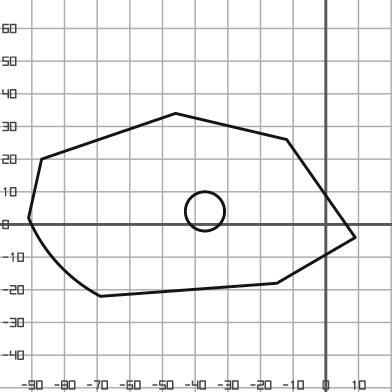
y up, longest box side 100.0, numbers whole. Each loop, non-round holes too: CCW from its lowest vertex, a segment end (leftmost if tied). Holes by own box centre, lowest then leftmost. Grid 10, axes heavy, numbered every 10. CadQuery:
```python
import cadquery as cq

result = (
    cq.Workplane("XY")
    .moveTo(-69.0, -22.0)
    .lineTo(-15.0, -18.0)
    .lineTo(9.0, -4.0)
    .lineTo(-12.0, 26.0)
    .lineTo(-46.0, 34.0)
    .lineTo(-87.0, 20.0)
    .lineTo(-91.0, 2.0)
    .threePointArc((-82.0, -12.0), (-69.0, -22.0))
    .close()
    .moveTo(-37.0, 4.0)
    .circle(6.0)
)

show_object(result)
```